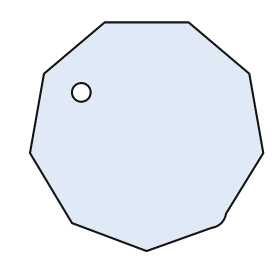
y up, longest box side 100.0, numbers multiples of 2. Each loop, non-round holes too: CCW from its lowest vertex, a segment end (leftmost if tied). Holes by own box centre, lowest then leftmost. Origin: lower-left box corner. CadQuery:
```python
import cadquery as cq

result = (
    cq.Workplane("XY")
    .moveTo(50.0, 0.0)
    .lineTo(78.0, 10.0)
    .threePointArc((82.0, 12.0), (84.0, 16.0))
    .lineTo(100.0, 42.0)
    .lineTo(94.0, 76.0)
    .lineTo(68.0, 98.0)
    .lineTo(32.0, 98.0)
    .lineTo(6.0, 76.0)
    .lineTo(0.0, 42.0)
    .lineTo(18.0, 12.0)
    .close()
    .moveTo(22.0, 68.0)
    .circle(4.0)
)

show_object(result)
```